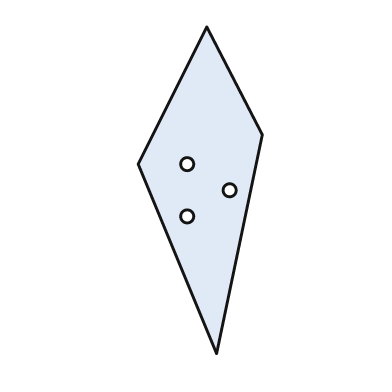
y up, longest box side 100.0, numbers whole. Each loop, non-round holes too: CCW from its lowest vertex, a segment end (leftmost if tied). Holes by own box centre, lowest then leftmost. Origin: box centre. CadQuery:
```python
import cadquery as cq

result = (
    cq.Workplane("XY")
    .moveTo(5.0, -50.0)
    .lineTo(19.0, 17.0)
    .lineTo(2.0, 50.0)
    .lineTo(-19.0, 8.0)
    .close()
    .moveTo(-4.0, -8.0)
    .circle(2.0)
    .moveTo(9.0, 0.0)
    .circle(2.0)
    .moveTo(-4.0, 8.0)
    .circle(2.0)
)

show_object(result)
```